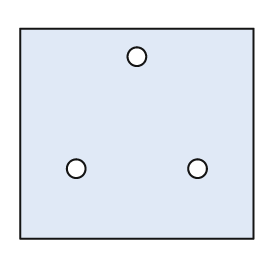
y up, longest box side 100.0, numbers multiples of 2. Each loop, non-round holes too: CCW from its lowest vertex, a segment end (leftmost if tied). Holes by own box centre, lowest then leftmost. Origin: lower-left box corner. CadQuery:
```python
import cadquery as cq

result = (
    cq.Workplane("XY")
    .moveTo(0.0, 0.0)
    .lineTo(100.0, 0.0)
    .lineTo(100.0, 90.0)
    .lineTo(0.0, 90.0)
    .close()
    .moveTo(24.0, 30.0)
    .circle(4.0)
    .moveTo(76.0, 30.0)
    .circle(4.0)
    .moveTo(50.0, 78.0)
    .circle(4.0)
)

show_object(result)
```